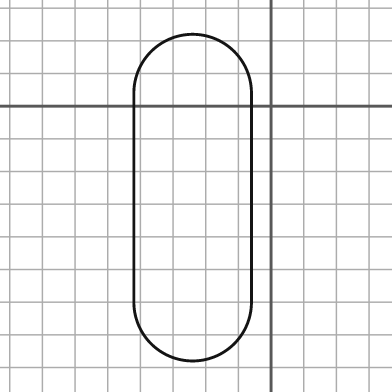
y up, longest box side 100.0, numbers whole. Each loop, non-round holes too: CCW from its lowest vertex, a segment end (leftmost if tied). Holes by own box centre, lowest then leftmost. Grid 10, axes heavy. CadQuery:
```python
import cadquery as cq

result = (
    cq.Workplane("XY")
    .moveTo(-42.0, -60.0)
    .threePointArc((-24.0, -78.0), (-6.0, -60.0))
    .lineTo(-6.0, 4.0)
    .threePointArc((-24.0, 22.0), (-42.0, 4.0))
    .close()
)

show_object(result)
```